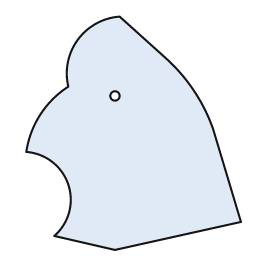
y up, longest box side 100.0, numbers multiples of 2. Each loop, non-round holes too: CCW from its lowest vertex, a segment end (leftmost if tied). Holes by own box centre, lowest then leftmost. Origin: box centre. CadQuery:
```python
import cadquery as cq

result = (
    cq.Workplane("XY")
    .moveTo(-8.0, -50.0)
    .lineTo(46.0, -38.0)
    .lineTo(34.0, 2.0)
    .threePointArc((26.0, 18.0), (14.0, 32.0))
    .lineTo(-6.0, 50.0)
    .threePointArc((-24.0, 40.0), (-28.0, 20.0))
    .threePointArc((-40.0, 8.0), (-46.0, -8.0))
    .threePointArc((-28.0, -22.0), (-34.0, -44.0))
    .close()
    .moveTo(-8.0, 16.0)
    .circle(2.0)
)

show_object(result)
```